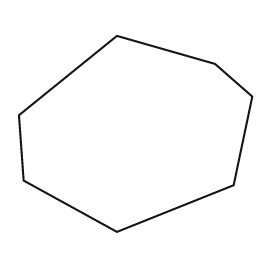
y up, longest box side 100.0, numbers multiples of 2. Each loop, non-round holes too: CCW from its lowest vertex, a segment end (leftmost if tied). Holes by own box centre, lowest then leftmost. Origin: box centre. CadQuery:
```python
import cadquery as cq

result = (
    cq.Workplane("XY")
    .moveTo(-8.0, -42.0)
    .lineTo(42.0, -22.0)
    .lineTo(50.0, 16.0)
    .lineTo(34.0, 30.0)
    .lineTo(-8.0, 42.0)
    .lineTo(-50.0, 8.0)
    .lineTo(-48.0, -20.0)
    .close()
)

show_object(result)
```